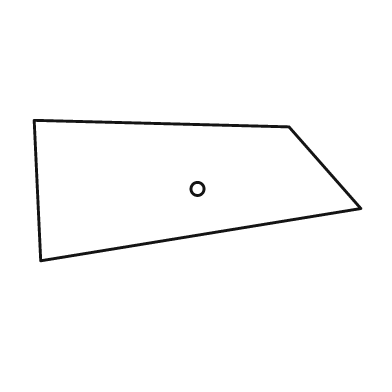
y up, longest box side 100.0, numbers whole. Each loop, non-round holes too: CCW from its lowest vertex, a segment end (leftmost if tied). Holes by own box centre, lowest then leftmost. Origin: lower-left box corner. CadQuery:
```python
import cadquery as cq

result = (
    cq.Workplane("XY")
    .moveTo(2.0, 0.0)
    .lineTo(100.0, 16.0)
    .lineTo(78.0, 41.0)
    .lineTo(0.0, 43.0)
    .close()
    .moveTo(50.0, 22.0)
    .circle(2.0)
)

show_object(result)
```